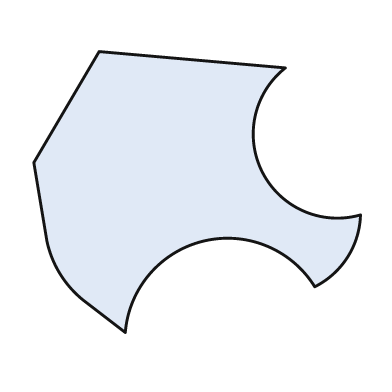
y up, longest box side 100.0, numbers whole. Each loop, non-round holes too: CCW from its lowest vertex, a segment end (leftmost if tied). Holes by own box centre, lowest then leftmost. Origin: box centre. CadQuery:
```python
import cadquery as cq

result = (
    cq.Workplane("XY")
    .moveTo(-22.0, -43.0)
    .threePointArc((2.0, -15.0), (36.0, -29.0))
    .threePointArc((46.0, -20.0), (50.0, -7.0))
    .threePointArc((20.0, 6.0), (27.0, 38.0))
    .lineTo(-30.0, 43.0)
    .lineTo(-50.0, 9.0)
    .lineTo(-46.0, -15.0)
    .threePointArc((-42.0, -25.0), (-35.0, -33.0))
    .close()
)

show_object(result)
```